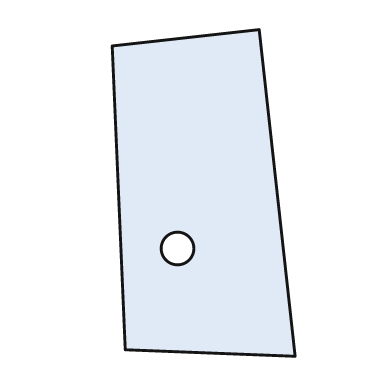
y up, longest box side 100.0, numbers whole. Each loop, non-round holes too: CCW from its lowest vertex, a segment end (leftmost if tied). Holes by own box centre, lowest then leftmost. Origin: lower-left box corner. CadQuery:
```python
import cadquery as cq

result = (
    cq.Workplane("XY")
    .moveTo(56.0, 0.0)
    .lineTo(45.0, 100.0)
    .lineTo(0.0, 95.0)
    .lineTo(4.0, 2.0)
    .close()
    .moveTo(20.0, 33.0)
    .circle(5.0)
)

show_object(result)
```